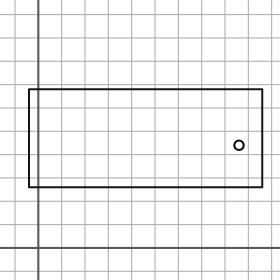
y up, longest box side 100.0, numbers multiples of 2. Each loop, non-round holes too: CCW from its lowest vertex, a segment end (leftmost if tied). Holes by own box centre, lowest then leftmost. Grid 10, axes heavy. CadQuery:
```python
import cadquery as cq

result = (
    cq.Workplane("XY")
    .moveTo(-4.0, 26.0)
    .lineTo(96.0, 26.0)
    .lineTo(96.0, 68.0)
    .lineTo(-4.0, 68.0)
    .close()
    .moveTo(86.0, 44.0)
    .circle(2.0)
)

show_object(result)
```